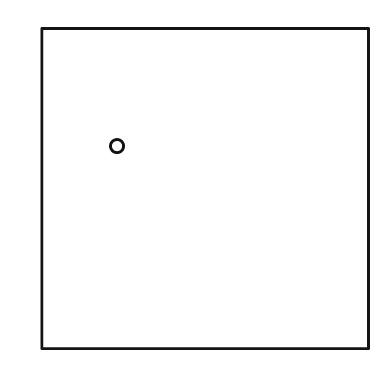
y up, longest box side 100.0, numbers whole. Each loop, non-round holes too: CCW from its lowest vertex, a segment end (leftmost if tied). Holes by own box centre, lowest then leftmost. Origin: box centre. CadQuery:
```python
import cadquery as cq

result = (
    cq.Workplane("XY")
    .moveTo(-50.0, -49.0)
    .lineTo(50.0, -49.0)
    .lineTo(50.0, 49.0)
    .lineTo(-50.0, 49.0)
    .close()
    .moveTo(-27.0, 13.0)
    .circle(2.0)
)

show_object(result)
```